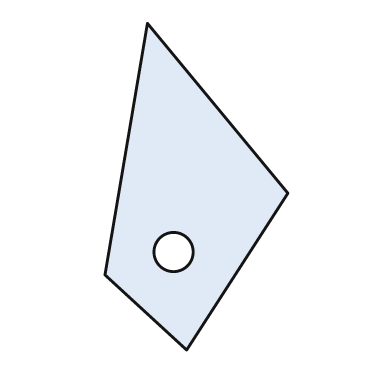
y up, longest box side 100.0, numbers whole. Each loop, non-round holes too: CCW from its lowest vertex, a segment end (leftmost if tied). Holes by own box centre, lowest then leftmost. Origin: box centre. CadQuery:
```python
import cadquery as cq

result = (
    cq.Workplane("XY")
    .moveTo(-3.0, -50.0)
    .lineTo(28.0, -2.0)
    .lineTo(-15.0, 50.0)
    .lineTo(-28.0, -27.0)
    .close()
    .moveTo(-7.0, -20.0)
    .circle(6.0)
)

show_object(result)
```